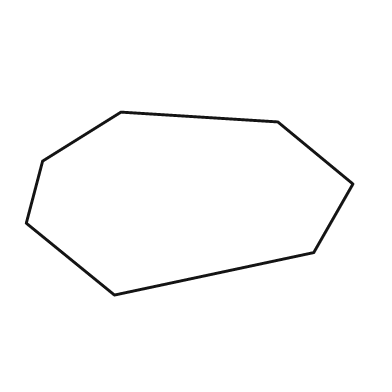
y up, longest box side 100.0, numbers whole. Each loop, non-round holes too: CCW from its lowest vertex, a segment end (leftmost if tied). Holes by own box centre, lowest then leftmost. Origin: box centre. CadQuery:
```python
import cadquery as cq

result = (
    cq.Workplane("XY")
    .moveTo(-23.0, -28.0)
    .lineTo(38.0, -15.0)
    .lineTo(50.0, 6.0)
    .lineTo(27.0, 25.0)
    .lineTo(-21.0, 28.0)
    .lineTo(-45.0, 13.0)
    .lineTo(-50.0, -6.0)
    .close()
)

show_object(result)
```